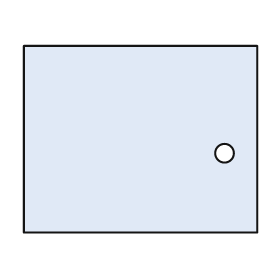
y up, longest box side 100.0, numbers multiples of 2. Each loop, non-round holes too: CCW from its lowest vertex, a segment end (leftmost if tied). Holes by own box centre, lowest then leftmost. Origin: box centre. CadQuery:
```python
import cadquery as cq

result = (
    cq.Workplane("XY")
    .moveTo(-50.0, -40.0)
    .lineTo(50.0, -40.0)
    .lineTo(50.0, 40.0)
    .lineTo(-50.0, 40.0)
    .close()
    .moveTo(36.0, -6.0)
    .circle(4.0)
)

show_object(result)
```